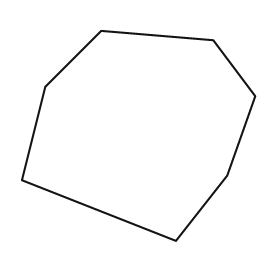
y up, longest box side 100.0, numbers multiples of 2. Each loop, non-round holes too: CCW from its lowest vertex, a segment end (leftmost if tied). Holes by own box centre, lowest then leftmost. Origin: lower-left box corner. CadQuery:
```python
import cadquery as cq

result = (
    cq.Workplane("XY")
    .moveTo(66.0, 0.0)
    .lineTo(88.0, 28.0)
    .lineTo(100.0, 62.0)
    .lineTo(82.0, 86.0)
    .lineTo(34.0, 90.0)
    .lineTo(10.0, 66.0)
    .lineTo(0.0, 26.0)
    .close()
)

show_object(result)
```